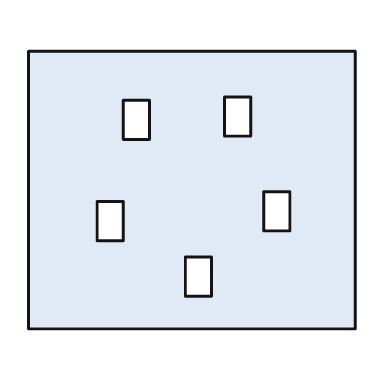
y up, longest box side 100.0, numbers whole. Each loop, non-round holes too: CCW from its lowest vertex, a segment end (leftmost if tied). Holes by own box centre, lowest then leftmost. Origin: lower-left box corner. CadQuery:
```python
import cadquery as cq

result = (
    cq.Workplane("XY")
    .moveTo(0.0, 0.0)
    .lineTo(100.0, 0.0)
    .lineTo(100.0, 85.0)
    .lineTo(0.0, 85.0)
    .close()
    .moveTo(48.0, 10.0)
    .lineTo(56.0, 10.0)
    .lineTo(56.0, 22.0)
    .lineTo(48.0, 22.0)
    .close()
    .moveTo(21.0, 27.0)
    .lineTo(29.0, 27.0)
    .lineTo(29.0, 39.0)
    .lineTo(21.0, 39.0)
    .close()
    .moveTo(72.0, 30.0)
    .lineTo(80.0, 30.0)
    .lineTo(80.0, 42.0)
    .lineTo(72.0, 42.0)
    .close()
    .moveTo(29.0, 58.0)
    .lineTo(37.0, 58.0)
    .lineTo(37.0, 70.0)
    .lineTo(29.0, 70.0)
    .close()
    .moveTo(60.0, 59.0)
    .lineTo(68.0, 59.0)
    .lineTo(68.0, 71.0)
    .lineTo(60.0, 71.0)
    .close()
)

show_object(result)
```